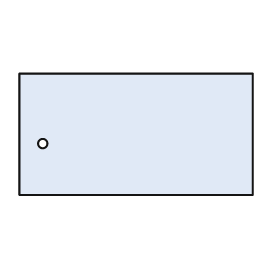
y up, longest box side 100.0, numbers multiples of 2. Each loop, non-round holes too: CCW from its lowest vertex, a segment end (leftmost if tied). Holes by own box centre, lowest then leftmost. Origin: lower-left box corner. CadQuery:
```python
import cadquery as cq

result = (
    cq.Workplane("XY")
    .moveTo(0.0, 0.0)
    .lineTo(100.0, 0.0)
    .lineTo(100.0, 52.0)
    .lineTo(0.0, 52.0)
    .close()
    .moveTo(10.0, 22.0)
    .circle(2.0)
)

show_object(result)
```